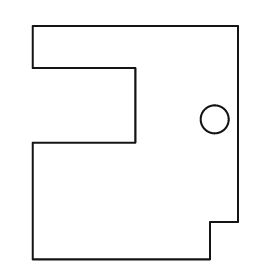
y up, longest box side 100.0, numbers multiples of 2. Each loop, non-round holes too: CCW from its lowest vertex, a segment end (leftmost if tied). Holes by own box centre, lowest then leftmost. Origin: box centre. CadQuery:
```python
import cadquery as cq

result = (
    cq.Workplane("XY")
    .moveTo(-44.0, -50.0)
    .lineTo(32.0, -50.0)
    .lineTo(32.0, -34.0)
    .lineTo(44.0, -34.0)
    .lineTo(44.0, 50.0)
    .lineTo(-44.0, 50.0)
    .lineTo(-44.0, 32.0)
    .lineTo(0.0, 32.0)
    .lineTo(0.0, 0.0)
    .lineTo(-44.0, 0.0)
    .close()
    .moveTo(34.0, 10.0)
    .circle(6.0)
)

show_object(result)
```